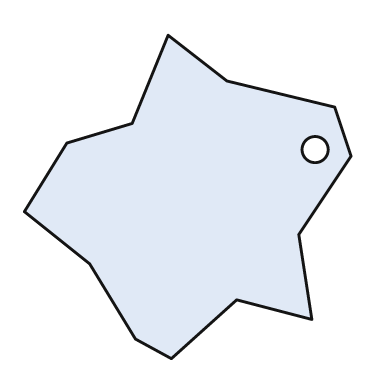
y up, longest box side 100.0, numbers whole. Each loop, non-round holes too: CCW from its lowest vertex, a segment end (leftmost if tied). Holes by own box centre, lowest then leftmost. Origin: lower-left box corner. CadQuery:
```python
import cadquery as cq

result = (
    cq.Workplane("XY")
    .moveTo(45.0, 0.0)
    .lineTo(65.0, 18.0)
    .lineTo(88.0, 12.0)
    .lineTo(84.0, 38.0)
    .lineTo(100.0, 62.0)
    .lineTo(95.0, 77.0)
    .lineTo(62.0, 85.0)
    .lineTo(44.0, 99.0)
    .lineTo(33.0, 72.0)
    .lineTo(13.0, 66.0)
    .lineTo(0.0, 45.0)
    .lineTo(20.0, 29.0)
    .lineTo(34.0, 6.0)
    .close()
    .moveTo(89.0, 64.0)
    .circle(4.0)
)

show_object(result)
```